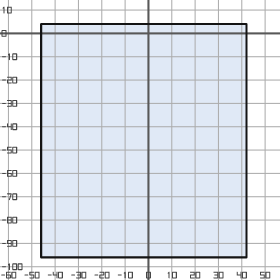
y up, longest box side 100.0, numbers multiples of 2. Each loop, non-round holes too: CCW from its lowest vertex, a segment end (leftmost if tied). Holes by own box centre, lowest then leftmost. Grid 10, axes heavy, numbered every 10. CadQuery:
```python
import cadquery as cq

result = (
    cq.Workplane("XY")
    .moveTo(-46.0, -96.0)
    .lineTo(42.0, -96.0)
    .lineTo(42.0, 4.0)
    .lineTo(-46.0, 4.0)
    .close()
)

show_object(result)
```